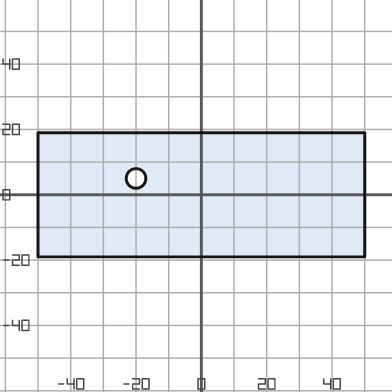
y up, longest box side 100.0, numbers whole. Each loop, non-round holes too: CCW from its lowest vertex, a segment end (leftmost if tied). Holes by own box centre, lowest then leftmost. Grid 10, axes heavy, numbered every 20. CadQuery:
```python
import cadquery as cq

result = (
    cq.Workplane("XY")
    .moveTo(-50.0, -19.0)
    .lineTo(50.0, -19.0)
    .lineTo(50.0, 19.0)
    .lineTo(-50.0, 19.0)
    .close()
    .moveTo(-20.0, 5.0)
    .circle(3.0)
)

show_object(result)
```